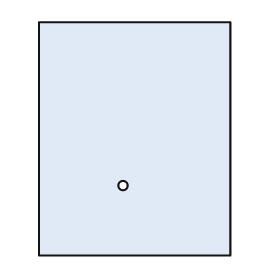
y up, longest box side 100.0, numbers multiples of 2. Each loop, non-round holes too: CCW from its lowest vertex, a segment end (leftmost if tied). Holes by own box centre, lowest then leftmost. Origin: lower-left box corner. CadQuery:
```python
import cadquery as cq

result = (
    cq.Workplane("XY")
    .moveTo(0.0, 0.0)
    .lineTo(82.0, 0.0)
    .lineTo(82.0, 100.0)
    .lineTo(0.0, 100.0)
    .close()
    .moveTo(36.0, 30.0)
    .circle(2.0)
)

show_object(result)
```